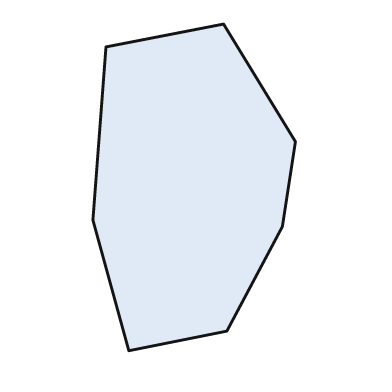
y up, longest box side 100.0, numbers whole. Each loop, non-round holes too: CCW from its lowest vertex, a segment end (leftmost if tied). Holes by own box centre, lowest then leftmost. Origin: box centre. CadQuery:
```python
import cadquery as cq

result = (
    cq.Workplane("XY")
    .moveTo(-20.0, -50.0)
    .lineTo(10.0, -44.0)
    .lineTo(27.0, -12.0)
    .lineTo(31.0, 14.0)
    .lineTo(9.0, 50.0)
    .lineTo(-27.0, 43.0)
    .lineTo(-31.0, -10.0)
    .close()
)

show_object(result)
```